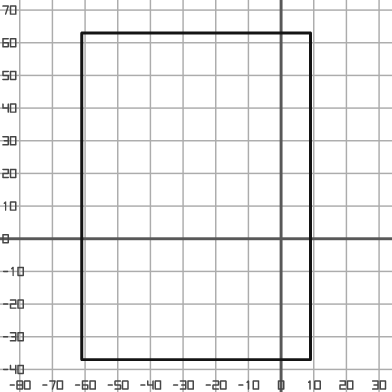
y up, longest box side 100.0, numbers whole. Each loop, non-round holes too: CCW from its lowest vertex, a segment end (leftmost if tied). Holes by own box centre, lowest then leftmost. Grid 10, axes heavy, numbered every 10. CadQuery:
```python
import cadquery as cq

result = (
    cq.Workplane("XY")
    .moveTo(-61.0, -37.0)
    .lineTo(9.0, -37.0)
    .lineTo(9.0, 63.0)
    .lineTo(-61.0, 63.0)
    .close()
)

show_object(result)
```